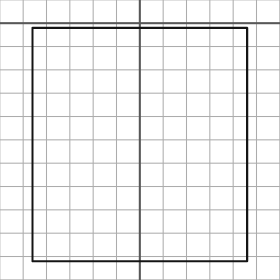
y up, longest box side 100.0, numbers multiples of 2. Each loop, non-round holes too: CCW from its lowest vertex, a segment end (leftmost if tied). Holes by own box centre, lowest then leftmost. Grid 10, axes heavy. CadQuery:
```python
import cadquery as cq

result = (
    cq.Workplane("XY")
    .moveTo(-46.0, -102.0)
    .lineTo(46.0, -102.0)
    .lineTo(46.0, -2.0)
    .lineTo(-46.0, -2.0)
    .close()
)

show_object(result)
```